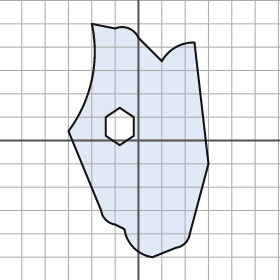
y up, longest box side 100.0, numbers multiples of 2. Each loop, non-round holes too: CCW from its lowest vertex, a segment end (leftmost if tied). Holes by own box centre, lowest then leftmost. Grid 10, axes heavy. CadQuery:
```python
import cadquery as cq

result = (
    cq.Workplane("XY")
    .moveTo(6.0, -50.0)
    .lineTo(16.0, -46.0)
    .threePointArc((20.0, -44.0), (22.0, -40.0))
    .lineTo(30.0, -10.0)
    .lineTo(24.0, 42.0)
    .threePointArc((16.0, 40.0), (10.0, 34.0))
    .lineTo(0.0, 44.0)
    .threePointArc((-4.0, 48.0), (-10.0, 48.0))
    .lineTo(-20.0, 50.0)
    .threePointArc((-20.0, 26.0), (-30.0, 4.0))
    .lineTo(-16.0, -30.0)
    .threePointArc((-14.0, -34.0), (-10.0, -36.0))
    .lineTo(-6.0, -38.0)
    .threePointArc((-2.0, -46.0), (6.0, -50.0))
    .close()
    .moveTo(-8.0, -2.0)
    .lineTo(-2.0, 2.0)
    .lineTo(-2.0, 10.0)
    .lineTo(-8.0, 14.0)
    .lineTo(-14.0, 10.0)
    .lineTo(-14.0, 2.0)
    .close()
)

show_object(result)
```